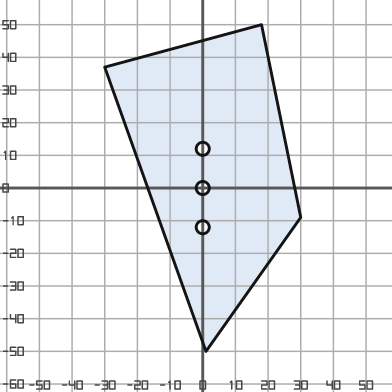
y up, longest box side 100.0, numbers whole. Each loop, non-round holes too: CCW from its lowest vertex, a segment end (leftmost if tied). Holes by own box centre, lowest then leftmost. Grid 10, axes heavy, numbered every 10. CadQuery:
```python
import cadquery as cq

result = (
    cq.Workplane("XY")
    .moveTo(1.0, -50.0)
    .lineTo(30.0, -9.0)
    .lineTo(18.0, 50.0)
    .lineTo(-30.0, 37.0)
    .close()
    .moveTo(0.0, -12.0)
    .circle(2.0)
    .moveTo(0.0, 0.0)
    .circle(2.0)
    .moveTo(0.0, 12.0)
    .circle(2.0)
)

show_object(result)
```